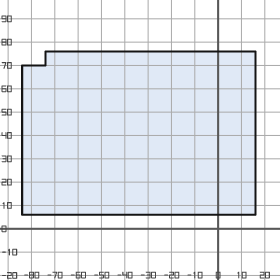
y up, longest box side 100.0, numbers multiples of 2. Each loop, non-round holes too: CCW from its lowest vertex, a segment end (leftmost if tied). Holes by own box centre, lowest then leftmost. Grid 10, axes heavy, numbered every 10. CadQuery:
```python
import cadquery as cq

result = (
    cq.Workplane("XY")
    .moveTo(-84.0, 6.0)
    .lineTo(16.0, 6.0)
    .lineTo(16.0, 76.0)
    .lineTo(-74.0, 76.0)
    .lineTo(-74.0, 70.0)
    .lineTo(-84.0, 70.0)
    .close()
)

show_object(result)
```